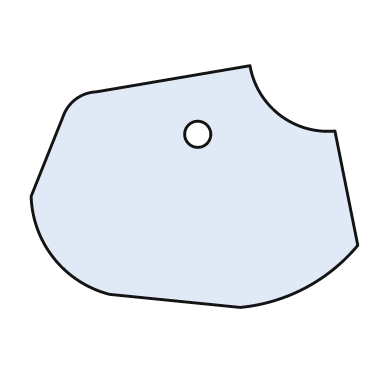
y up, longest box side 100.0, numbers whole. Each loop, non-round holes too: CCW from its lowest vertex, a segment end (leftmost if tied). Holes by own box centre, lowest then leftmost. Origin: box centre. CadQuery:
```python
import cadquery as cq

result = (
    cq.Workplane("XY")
    .moveTo(14.0, -37.0)
    .threePointArc((34.0, -31.0), (50.0, -18.0))
    .lineTo(43.0, 17.0)
    .threePointArc((26.0, 22.0), (17.0, 37.0))
    .lineTo(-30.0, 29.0)
    .threePointArc((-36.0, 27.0), (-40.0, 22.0))
    .lineTo(-50.0, -3.0)
    .threePointArc((-43.0, -22.0), (-26.0, -33.0))
    .close()
    .moveTo(1.0, 16.0)
    .circle(4.0)
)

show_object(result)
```